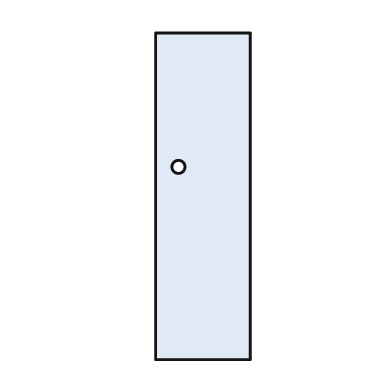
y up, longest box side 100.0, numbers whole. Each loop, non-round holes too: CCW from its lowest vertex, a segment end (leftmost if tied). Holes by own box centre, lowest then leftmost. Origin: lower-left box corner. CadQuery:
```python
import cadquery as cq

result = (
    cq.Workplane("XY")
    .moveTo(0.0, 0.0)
    .lineTo(29.0, 0.0)
    .lineTo(29.0, 100.0)
    .lineTo(0.0, 100.0)
    .close()
    .moveTo(7.0, 59.0)
    .circle(2.0)
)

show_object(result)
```